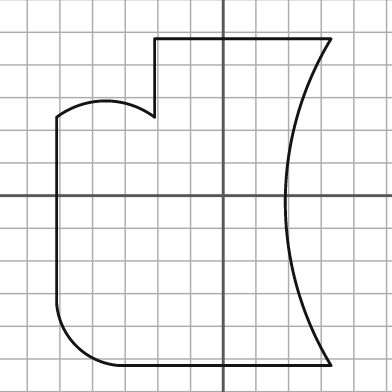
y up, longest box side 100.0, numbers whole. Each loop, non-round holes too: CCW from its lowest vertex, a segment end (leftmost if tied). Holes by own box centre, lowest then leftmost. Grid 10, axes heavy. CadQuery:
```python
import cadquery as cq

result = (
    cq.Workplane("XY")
    .moveTo(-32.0, -52.0)
    .lineTo(33.0, -52.0)
    .threePointArc((19.0, -2.0), (33.0, 48.0))
    .lineTo(-21.0, 48.0)
    .lineTo(-21.0, 24.0)
    .threePointArc((-36.0, 29.0), (-51.0, 24.0))
    .lineTo(-51.0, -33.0)
    .threePointArc((-45.0, -46.0), (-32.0, -52.0))
    .close()
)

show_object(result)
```